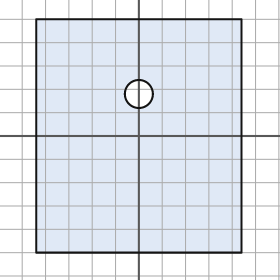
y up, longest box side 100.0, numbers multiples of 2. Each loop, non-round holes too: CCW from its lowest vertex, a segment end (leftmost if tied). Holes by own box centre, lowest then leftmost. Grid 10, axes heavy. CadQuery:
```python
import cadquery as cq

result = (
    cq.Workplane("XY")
    .moveTo(-44.0, -50.0)
    .lineTo(44.0, -50.0)
    .lineTo(44.0, 50.0)
    .lineTo(-44.0, 50.0)
    .close()
    .moveTo(0.0, 18.0)
    .circle(6.0)
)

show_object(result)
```